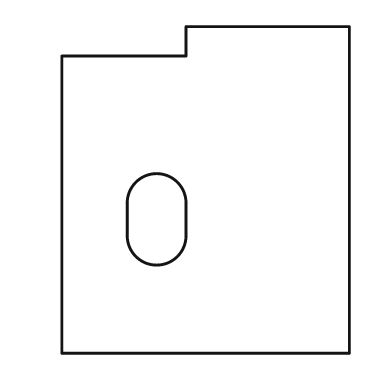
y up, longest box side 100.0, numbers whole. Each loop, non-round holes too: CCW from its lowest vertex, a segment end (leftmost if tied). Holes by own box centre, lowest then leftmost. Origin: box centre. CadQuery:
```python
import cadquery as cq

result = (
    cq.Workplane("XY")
    .moveTo(-44.0, -50.0)
    .lineTo(44.0, -50.0)
    .lineTo(44.0, 50.0)
    .lineTo(-6.0, 50.0)
    .lineTo(-6.0, 41.0)
    .lineTo(-44.0, 41.0)
    .close()
    .moveTo(-24.0, -14.0)
    .threePointArc((-15.0, -23.0), (-6.0, -14.0))
    .lineTo(-6.0, -4.0)
    .threePointArc((-15.0, 5.0), (-24.0, -4.0))
    .close()
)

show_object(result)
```